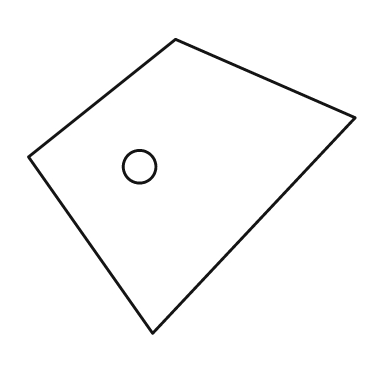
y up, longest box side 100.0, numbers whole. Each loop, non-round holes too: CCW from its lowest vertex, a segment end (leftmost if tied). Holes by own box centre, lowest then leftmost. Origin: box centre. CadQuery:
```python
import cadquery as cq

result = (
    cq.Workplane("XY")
    .moveTo(-12.0, -45.0)
    .lineTo(50.0, 21.0)
    .lineTo(-5.0, 45.0)
    .lineTo(-50.0, 9.0)
    .close()
    .moveTo(-16.0, 6.0)
    .circle(5.0)
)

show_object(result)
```